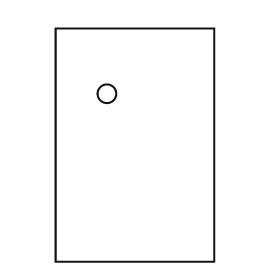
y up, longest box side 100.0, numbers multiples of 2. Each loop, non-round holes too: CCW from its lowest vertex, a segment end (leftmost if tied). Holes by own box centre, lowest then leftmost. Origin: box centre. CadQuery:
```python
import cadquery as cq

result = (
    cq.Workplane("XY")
    .moveTo(-34.0, -50.0)
    .lineTo(34.0, -50.0)
    .lineTo(34.0, 50.0)
    .lineTo(-34.0, 50.0)
    .close()
    .moveTo(-12.0, 22.0)
    .circle(4.0)
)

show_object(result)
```